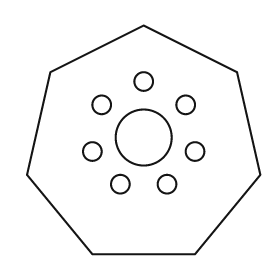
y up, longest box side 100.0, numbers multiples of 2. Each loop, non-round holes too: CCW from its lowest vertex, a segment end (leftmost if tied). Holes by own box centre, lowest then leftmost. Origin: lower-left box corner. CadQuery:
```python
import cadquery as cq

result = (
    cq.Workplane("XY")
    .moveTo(28.0, 0.0)
    .lineTo(72.0, 0.0)
    .lineTo(100.0, 34.0)
    .lineTo(90.0, 78.0)
    .lineTo(50.0, 98.0)
    .lineTo(10.0, 78.0)
    .lineTo(0.0, 34.0)
    .close()
    .moveTo(40.0, 30.0)
    .circle(4.0)
    .moveTo(60.0, 30.0)
    .circle(4.0)
    .moveTo(28.0, 44.0)
    .circle(4.0)
    .moveTo(72.0, 44.0)
    .circle(4.0)
    .moveTo(50.0, 50.0)
    .circle(12.0)
    .moveTo(32.0, 64.0)
    .circle(4.0)
    .moveTo(68.0, 64.0)
    .circle(4.0)
    .moveTo(50.0, 74.0)
    .circle(4.0)
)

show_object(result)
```